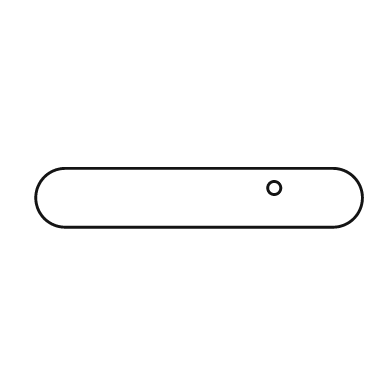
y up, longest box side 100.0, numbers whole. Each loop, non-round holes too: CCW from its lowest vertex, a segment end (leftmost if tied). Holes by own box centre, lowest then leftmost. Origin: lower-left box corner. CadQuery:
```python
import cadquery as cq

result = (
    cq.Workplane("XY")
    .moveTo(9.0, 0.0)
    .lineTo(91.0, 0.0)
    .threePointArc((100.0, 9.0), (91.0, 18.0))
    .lineTo(9.0, 18.0)
    .threePointArc((0.0, 9.0), (9.0, 0.0))
    .close()
    .moveTo(73.0, 12.0)
    .circle(2.0)
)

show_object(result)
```